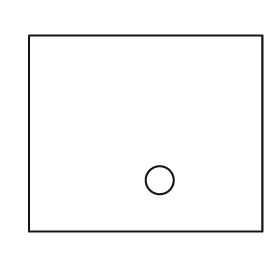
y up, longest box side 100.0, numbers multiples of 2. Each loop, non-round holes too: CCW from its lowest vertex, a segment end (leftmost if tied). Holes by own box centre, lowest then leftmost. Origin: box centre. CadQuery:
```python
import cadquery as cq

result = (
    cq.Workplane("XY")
    .moveTo(-50.0, -42.0)
    .lineTo(50.0, -42.0)
    .lineTo(50.0, 42.0)
    .lineTo(-50.0, 42.0)
    .close()
    .moveTo(6.0, -20.0)
    .circle(6.0)
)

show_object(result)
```